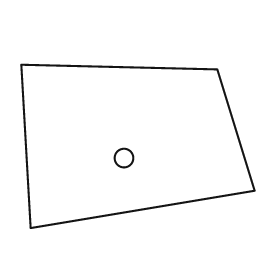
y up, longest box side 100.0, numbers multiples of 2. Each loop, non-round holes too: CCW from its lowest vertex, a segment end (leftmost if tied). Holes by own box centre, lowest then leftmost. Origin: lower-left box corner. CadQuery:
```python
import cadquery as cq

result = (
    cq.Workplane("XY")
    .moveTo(4.0, 0.0)
    .lineTo(100.0, 16.0)
    .lineTo(84.0, 68.0)
    .lineTo(0.0, 70.0)
    .close()
    .moveTo(44.0, 30.0)
    .circle(4.0)
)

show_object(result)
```